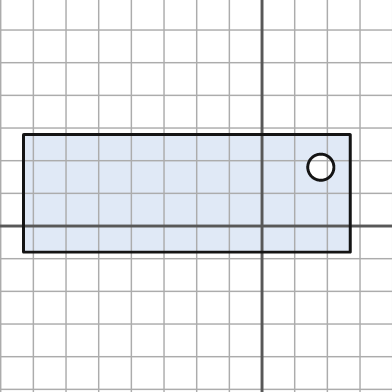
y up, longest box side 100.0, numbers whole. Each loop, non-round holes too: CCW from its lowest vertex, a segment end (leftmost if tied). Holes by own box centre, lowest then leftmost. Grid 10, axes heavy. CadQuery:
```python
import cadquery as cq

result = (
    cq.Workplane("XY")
    .moveTo(-73.0, -8.0)
    .lineTo(27.0, -8.0)
    .lineTo(27.0, 28.0)
    .lineTo(-73.0, 28.0)
    .close()
    .moveTo(18.0, 18.0)
    .circle(4.0)
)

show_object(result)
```